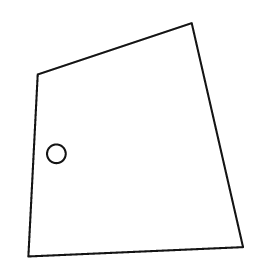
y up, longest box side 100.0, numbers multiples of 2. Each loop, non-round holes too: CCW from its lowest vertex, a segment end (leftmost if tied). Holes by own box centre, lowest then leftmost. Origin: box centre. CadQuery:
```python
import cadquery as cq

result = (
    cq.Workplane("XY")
    .moveTo(-46.0, -50.0)
    .lineTo(46.0, -46.0)
    .lineTo(24.0, 50.0)
    .lineTo(-42.0, 28.0)
    .close()
    .moveTo(-34.0, -6.0)
    .circle(4.0)
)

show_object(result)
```